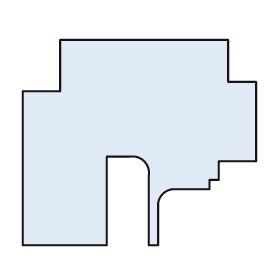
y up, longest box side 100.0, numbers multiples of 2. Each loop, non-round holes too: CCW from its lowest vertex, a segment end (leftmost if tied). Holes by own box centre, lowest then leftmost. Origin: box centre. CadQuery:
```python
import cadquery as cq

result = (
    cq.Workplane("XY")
    .moveTo(-50.0, -44.0)
    .lineTo(-14.0, -44.0)
    .lineTo(-14.0, -6.0)
    .lineTo(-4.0, -6.0)
    .threePointArc((2.0, -8.0), (4.0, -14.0))
    .lineTo(4.0, -44.0)
    .lineTo(8.0, -44.0)
    .lineTo(8.0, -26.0)
    .threePointArc((10.0, -22.0), (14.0, -20.0))
    .lineTo(30.0, -20.0)
    .lineTo(30.0, -16.0)
    .lineTo(34.0, -16.0)
    .lineTo(34.0, -8.0)
    .lineTo(50.0, -8.0)
    .lineTo(50.0, 26.0)
    .lineTo(38.0, 26.0)
    .lineTo(38.0, 44.0)
    .lineTo(-34.0, 44.0)
    .lineTo(-34.0, 22.0)
    .lineTo(-50.0, 22.0)
    .close()
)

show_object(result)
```